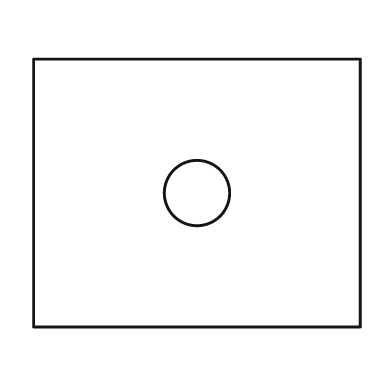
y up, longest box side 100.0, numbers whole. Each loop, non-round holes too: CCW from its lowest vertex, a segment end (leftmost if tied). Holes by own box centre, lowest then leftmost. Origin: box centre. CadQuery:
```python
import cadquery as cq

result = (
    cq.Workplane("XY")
    .moveTo(-50.0, -41.0)
    .lineTo(50.0, -41.0)
    .lineTo(50.0, 41.0)
    .lineTo(-50.0, 41.0)
    .close()
    .moveTo(0.0, 0.0)
    .circle(10.0)
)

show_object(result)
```